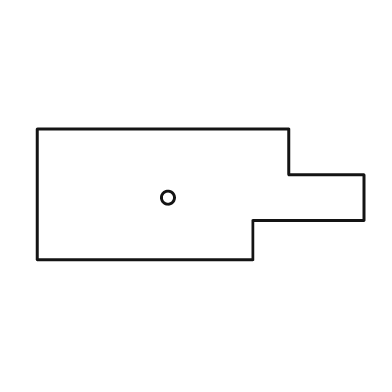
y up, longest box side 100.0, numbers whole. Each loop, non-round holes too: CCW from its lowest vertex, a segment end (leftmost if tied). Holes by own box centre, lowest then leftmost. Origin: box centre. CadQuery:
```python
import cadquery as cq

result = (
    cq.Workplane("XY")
    .moveTo(-50.0, -20.0)
    .lineTo(16.0, -20.0)
    .lineTo(16.0, -8.0)
    .lineTo(50.0, -8.0)
    .lineTo(50.0, 6.0)
    .lineTo(27.0, 6.0)
    .lineTo(27.0, 20.0)
    .lineTo(-50.0, 20.0)
    .close()
    .moveTo(-10.0, -1.0)
    .circle(2.0)
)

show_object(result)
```